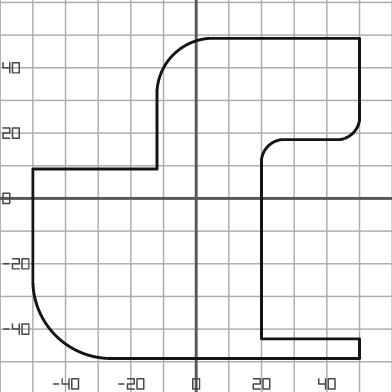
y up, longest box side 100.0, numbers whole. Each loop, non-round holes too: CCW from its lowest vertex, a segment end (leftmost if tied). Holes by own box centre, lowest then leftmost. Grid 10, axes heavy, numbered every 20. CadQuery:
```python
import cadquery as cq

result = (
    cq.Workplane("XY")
    .moveTo(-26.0, -49.0)
    .lineTo(50.0, -49.0)
    .lineTo(50.0, -43.0)
    .lineTo(20.0, -43.0)
    .lineTo(20.0, 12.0)
    .threePointArc((22.0, 16.0), (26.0, 18.0))
    .lineTo(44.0, 18.0)
    .threePointArc((48.0, 20.0), (50.0, 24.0))
    .lineTo(50.0, 49.0)
    .lineTo(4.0, 49.0)
    .threePointArc((-7.0, 44.0), (-12.0, 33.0))
    .lineTo(-12.0, 9.0)
    .lineTo(-50.0, 9.0)
    .lineTo(-50.0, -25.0)
    .threePointArc((-43.0, -42.0), (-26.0, -49.0))
    .close()
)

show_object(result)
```